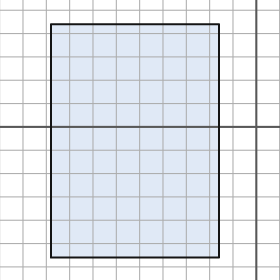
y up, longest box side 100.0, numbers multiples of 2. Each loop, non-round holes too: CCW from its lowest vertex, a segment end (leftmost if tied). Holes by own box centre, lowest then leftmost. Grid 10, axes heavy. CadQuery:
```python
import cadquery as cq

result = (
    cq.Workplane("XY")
    .moveTo(-88.0, -56.0)
    .lineTo(-16.0, -56.0)
    .lineTo(-16.0, 44.0)
    .lineTo(-88.0, 44.0)
    .close()
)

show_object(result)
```